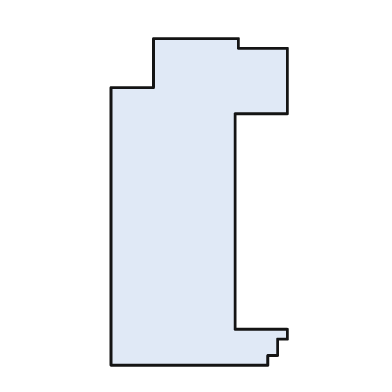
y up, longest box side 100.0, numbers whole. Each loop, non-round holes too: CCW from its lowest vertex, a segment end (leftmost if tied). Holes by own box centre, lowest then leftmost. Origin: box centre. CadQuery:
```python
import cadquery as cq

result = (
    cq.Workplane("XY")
    .moveTo(-27.0, -50.0)
    .lineTo(21.0, -50.0)
    .lineTo(21.0, -47.0)
    .lineTo(24.0, -47.0)
    .lineTo(24.0, -42.0)
    .lineTo(27.0, -42.0)
    .lineTo(27.0, -39.0)
    .lineTo(11.0, -39.0)
    .lineTo(11.0, 27.0)
    .lineTo(27.0, 27.0)
    .lineTo(27.0, 47.0)
    .lineTo(12.0, 47.0)
    .lineTo(12.0, 50.0)
    .lineTo(-14.0, 50.0)
    .lineTo(-14.0, 35.0)
    .lineTo(-27.0, 35.0)
    .close()
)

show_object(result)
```